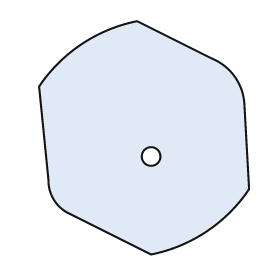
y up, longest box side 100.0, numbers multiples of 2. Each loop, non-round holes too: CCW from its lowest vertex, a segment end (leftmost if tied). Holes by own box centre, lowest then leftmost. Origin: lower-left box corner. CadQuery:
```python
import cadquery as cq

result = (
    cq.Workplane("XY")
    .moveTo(48.0, 0.0)
    .threePointArc((72.0, 10.0), (90.0, 28.0))
    .lineTo(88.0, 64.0)
    .threePointArc((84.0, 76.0), (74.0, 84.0))
    .lineTo(42.0, 100.0)
    .threePointArc((18.0, 90.0), (0.0, 72.0))
    .lineTo(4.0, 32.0)
    .threePointArc((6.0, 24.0), (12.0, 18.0))
    .close()
    .moveTo(48.0, 42.0)
    .circle(4.0)
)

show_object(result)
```